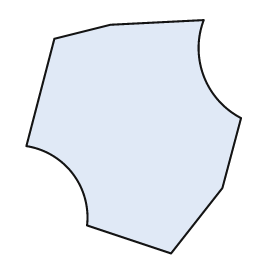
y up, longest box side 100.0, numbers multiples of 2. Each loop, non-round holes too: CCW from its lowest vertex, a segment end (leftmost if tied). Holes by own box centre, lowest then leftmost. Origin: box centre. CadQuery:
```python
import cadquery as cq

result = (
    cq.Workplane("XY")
    .moveTo(16.0, -50.0)
    .lineTo(38.0, -22.0)
    .lineTo(46.0, 8.0)
    .threePointArc((30.0, 26.0), (30.0, 50.0))
    .lineTo(-10.0, 48.0)
    .lineTo(-34.0, 42.0)
    .lineTo(-46.0, -4.0)
    .threePointArc((-26.0, -16.0), (-20.0, -38.0))
    .close()
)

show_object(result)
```